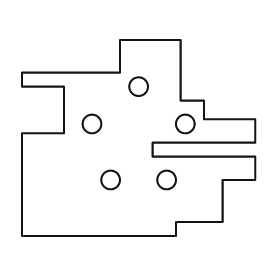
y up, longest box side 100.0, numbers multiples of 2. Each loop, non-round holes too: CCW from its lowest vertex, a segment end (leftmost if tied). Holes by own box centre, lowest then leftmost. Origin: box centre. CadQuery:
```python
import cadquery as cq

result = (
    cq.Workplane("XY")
    .moveTo(-50.0, -42.0)
    .lineTo(16.0, -42.0)
    .lineTo(16.0, -36.0)
    .lineTo(36.0, -36.0)
    .lineTo(36.0, -18.0)
    .lineTo(50.0, -18.0)
    .lineTo(50.0, -8.0)
    .lineTo(6.0, -8.0)
    .lineTo(6.0, -2.0)
    .lineTo(50.0, -2.0)
    .lineTo(50.0, 8.0)
    .lineTo(28.0, 8.0)
    .lineTo(28.0, 16.0)
    .lineTo(18.0, 16.0)
    .lineTo(18.0, 42.0)
    .lineTo(-8.0, 42.0)
    .lineTo(-8.0, 28.0)
    .lineTo(-50.0, 28.0)
    .lineTo(-50.0, 22.0)
    .lineTo(-32.0, 22.0)
    .lineTo(-32.0, 2.0)
    .lineTo(-50.0, 2.0)
    .close()
    .moveTo(-12.0, -18.0)
    .circle(4.0)
    .moveTo(12.0, -18.0)
    .circle(4.0)
    .moveTo(-20.0, 6.0)
    .circle(4.0)
    .moveTo(20.0, 6.0)
    .circle(4.0)
    .moveTo(0.0, 22.0)
    .circle(4.0)
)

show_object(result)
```